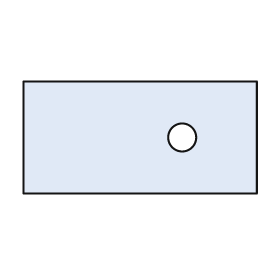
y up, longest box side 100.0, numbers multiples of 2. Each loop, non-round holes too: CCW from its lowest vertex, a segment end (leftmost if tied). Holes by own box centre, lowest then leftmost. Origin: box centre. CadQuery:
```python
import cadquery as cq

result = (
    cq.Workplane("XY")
    .moveTo(-50.0, -24.0)
    .lineTo(50.0, -24.0)
    .lineTo(50.0, 24.0)
    .lineTo(-50.0, 24.0)
    .close()
    .moveTo(18.0, 0.0)
    .circle(6.0)
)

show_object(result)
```